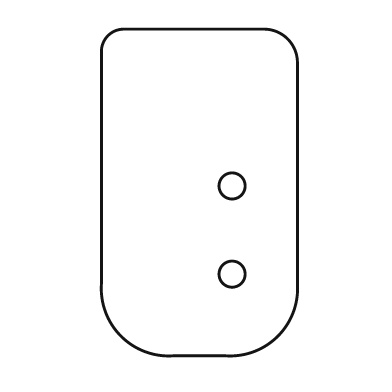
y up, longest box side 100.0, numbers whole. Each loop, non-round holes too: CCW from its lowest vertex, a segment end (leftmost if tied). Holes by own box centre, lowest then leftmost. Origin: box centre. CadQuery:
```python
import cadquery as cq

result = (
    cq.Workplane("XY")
    .moveTo(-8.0, -50.0)
    .lineTo(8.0, -50.0)
    .threePointArc((24.0, -44.0), (30.0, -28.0))
    .lineTo(30.0, 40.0)
    .threePointArc((27.0, 47.0), (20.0, 50.0))
    .lineTo(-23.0, 50.0)
    .threePointArc((-28.0, 48.0), (-30.0, 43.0))
    .lineTo(-30.0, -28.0)
    .threePointArc((-24.0, -44.0), (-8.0, -50.0))
    .close()
    .moveTo(10.0, -25.0)
    .circle(4.0)
    .moveTo(10.0, 2.0)
    .circle(4.0)
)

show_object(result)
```